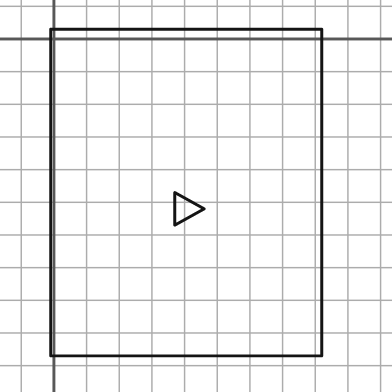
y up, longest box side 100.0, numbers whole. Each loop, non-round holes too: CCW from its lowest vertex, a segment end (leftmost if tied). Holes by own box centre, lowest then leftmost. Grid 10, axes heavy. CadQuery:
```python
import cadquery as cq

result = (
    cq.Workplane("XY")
    .moveTo(-1.0, -97.0)
    .lineTo(82.0, -97.0)
    .lineTo(82.0, 3.0)
    .lineTo(-1.0, 3.0)
    .close()
    .moveTo(37.0, -57.0)
    .lineTo(46.0, -52.0)
    .lineTo(37.0, -47.0)
    .close()
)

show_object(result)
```